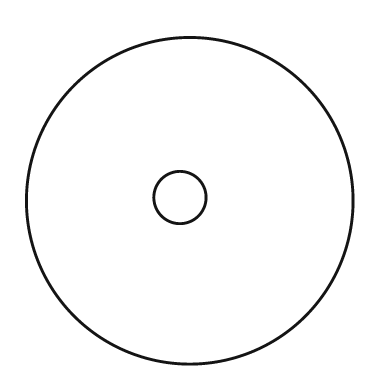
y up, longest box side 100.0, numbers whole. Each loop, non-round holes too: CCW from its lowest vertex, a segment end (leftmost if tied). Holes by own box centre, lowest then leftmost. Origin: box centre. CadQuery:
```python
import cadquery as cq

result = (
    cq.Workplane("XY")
    .moveTo(0.0, 0.0)
    .circle(50.0)
    .moveTo(-3.0, 1.0)
    .circle(8.0)
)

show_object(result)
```